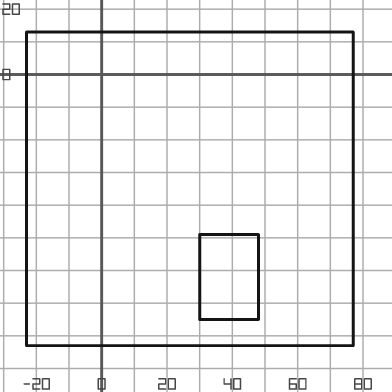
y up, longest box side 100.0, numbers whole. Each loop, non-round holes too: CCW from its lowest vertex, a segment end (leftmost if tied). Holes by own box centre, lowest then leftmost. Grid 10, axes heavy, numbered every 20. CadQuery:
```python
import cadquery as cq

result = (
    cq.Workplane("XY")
    .moveTo(-23.0, -83.0)
    .lineTo(77.0, -83.0)
    .lineTo(77.0, 13.0)
    .lineTo(-23.0, 13.0)
    .close()
    .moveTo(30.0, -75.0)
    .lineTo(48.0, -75.0)
    .lineTo(48.0, -49.0)
    .lineTo(30.0, -49.0)
    .close()
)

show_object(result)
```